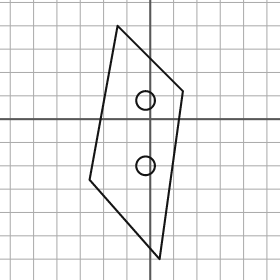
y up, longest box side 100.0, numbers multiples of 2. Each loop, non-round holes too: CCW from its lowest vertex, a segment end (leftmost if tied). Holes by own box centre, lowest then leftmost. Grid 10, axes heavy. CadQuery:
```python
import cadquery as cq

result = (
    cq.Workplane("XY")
    .moveTo(4.0, -60.0)
    .lineTo(14.0, 12.0)
    .lineTo(-14.0, 40.0)
    .lineTo(-26.0, -26.0)
    .close()
    .moveTo(-2.0, -20.0)
    .circle(4.0)
    .moveTo(-2.0, 8.0)
    .circle(4.0)
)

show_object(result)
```